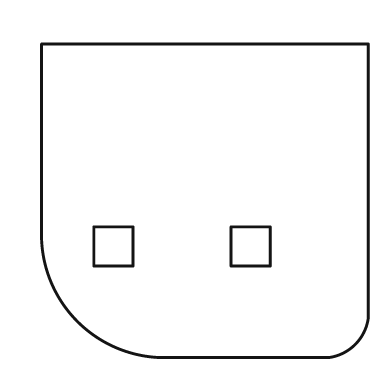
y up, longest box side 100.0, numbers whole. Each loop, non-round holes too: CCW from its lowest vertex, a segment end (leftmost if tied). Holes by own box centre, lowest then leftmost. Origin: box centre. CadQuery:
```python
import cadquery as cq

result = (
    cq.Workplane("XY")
    .moveTo(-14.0, -48.0)
    .lineTo(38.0, -48.0)
    .threePointArc((46.0, -44.0), (50.0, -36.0))
    .lineTo(50.0, 48.0)
    .lineTo(-50.0, 48.0)
    .lineTo(-50.0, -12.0)
    .threePointArc((-39.0, -37.0), (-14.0, -48.0))
    .close()
    .moveTo(-34.0, -20.0)
    .lineTo(-22.0, -20.0)
    .lineTo(-22.0, -8.0)
    .lineTo(-34.0, -8.0)
    .close()
    .moveTo(8.0, -20.0)
    .lineTo(20.0, -20.0)
    .lineTo(20.0, -8.0)
    .lineTo(8.0, -8.0)
    .close()
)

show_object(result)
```